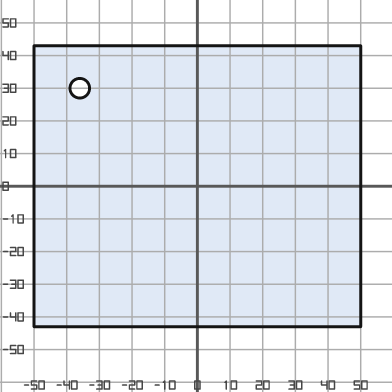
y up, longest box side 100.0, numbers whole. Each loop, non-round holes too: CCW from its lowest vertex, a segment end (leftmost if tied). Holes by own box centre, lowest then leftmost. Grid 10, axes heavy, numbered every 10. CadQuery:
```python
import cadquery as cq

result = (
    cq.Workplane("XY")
    .moveTo(-50.0, -43.0)
    .lineTo(50.0, -43.0)
    .lineTo(50.0, 43.0)
    .lineTo(-50.0, 43.0)
    .close()
    .moveTo(-36.0, 30.0)
    .circle(3.0)
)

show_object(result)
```